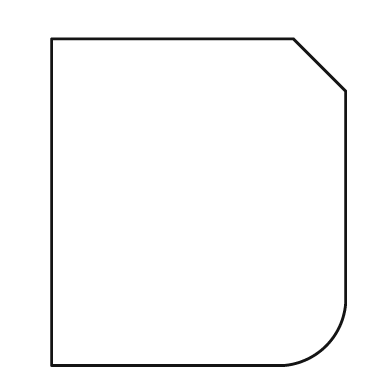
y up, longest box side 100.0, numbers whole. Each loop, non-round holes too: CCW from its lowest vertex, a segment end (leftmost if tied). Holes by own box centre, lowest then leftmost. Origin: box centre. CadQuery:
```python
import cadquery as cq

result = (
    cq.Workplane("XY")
    .moveTo(-45.0, -50.0)
    .lineTo(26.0, -50.0)
    .threePointArc((39.0, -44.0), (45.0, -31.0))
    .lineTo(45.0, 34.0)
    .lineTo(29.0, 50.0)
    .lineTo(-45.0, 50.0)
    .close()
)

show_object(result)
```